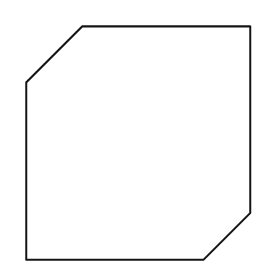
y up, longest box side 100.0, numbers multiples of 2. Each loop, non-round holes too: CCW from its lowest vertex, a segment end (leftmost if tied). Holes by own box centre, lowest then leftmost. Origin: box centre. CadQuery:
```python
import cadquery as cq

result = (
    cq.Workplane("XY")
    .moveTo(-48.0, -50.0)
    .lineTo(28.0, -50.0)
    .lineTo(48.0, -30.0)
    .lineTo(48.0, 50.0)
    .lineTo(-24.0, 50.0)
    .lineTo(-48.0, 26.0)
    .close()
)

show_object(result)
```